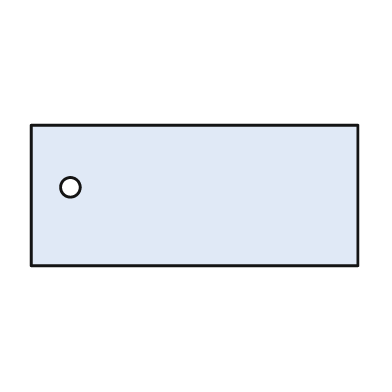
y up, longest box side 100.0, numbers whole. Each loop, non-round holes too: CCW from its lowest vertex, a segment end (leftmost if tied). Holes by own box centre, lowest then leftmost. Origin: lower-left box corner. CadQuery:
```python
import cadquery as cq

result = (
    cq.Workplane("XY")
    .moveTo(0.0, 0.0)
    .lineTo(100.0, 0.0)
    .lineTo(100.0, 43.0)
    .lineTo(0.0, 43.0)
    .close()
    .moveTo(12.0, 24.0)
    .circle(3.0)
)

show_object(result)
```